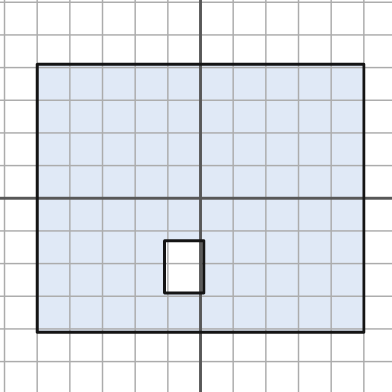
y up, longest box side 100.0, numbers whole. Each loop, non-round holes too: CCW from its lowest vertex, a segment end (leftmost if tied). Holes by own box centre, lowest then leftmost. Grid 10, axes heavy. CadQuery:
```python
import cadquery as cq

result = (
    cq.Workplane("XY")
    .moveTo(-50.0, -41.0)
    .lineTo(50.0, -41.0)
    .lineTo(50.0, 41.0)
    .lineTo(-50.0, 41.0)
    .close()
    .moveTo(-11.0, -29.0)
    .lineTo(1.0, -29.0)
    .lineTo(1.0, -13.0)
    .lineTo(-11.0, -13.0)
    .close()
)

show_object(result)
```